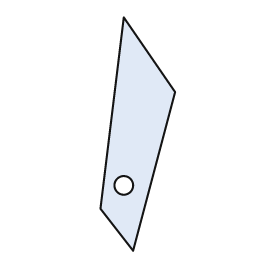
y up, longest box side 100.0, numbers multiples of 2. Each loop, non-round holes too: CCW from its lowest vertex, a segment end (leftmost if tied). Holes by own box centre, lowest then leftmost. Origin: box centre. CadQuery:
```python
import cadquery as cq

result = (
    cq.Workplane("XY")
    .moveTo(-2.0, -50.0)
    .lineTo(16.0, 18.0)
    .lineTo(-6.0, 50.0)
    .lineTo(-16.0, -32.0)
    .close()
    .moveTo(-6.0, -22.0)
    .circle(4.0)
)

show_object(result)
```